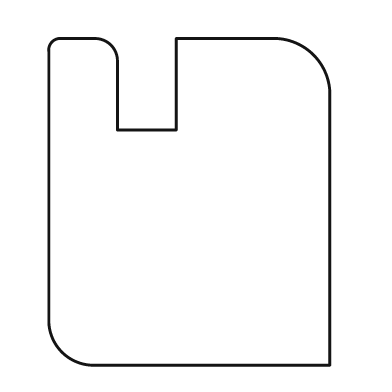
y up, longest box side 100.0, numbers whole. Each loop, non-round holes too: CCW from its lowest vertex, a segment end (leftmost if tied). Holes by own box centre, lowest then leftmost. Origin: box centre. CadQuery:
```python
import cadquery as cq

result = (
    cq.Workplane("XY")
    .moveTo(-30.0, -50.0)
    .lineTo(43.0, -50.0)
    .lineTo(43.0, 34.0)
    .threePointArc((38.0, 45.0), (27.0, 50.0))
    .lineTo(-4.0, 50.0)
    .lineTo(-4.0, 22.0)
    .lineTo(-22.0, 22.0)
    .lineTo(-22.0, 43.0)
    .threePointArc((-24.0, 48.0), (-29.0, 50.0))
    .lineTo(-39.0, 50.0)
    .threePointArc((-42.0, 49.0), (-43.0, 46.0))
    .lineTo(-43.0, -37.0)
    .threePointArc((-39.0, -46.0), (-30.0, -50.0))
    .close()
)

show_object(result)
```